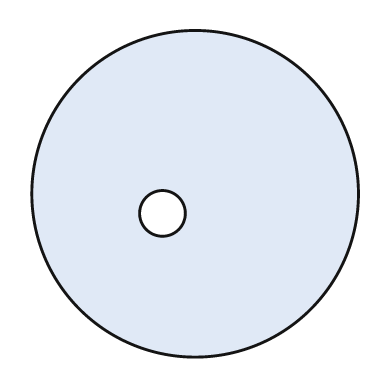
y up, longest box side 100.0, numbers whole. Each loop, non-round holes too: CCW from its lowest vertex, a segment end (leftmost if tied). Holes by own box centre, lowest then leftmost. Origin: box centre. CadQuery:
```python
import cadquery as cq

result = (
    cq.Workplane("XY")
    .moveTo(0.0, 0.0)
    .circle(50.0)
    .moveTo(-10.0, -6.0)
    .circle(7.0)
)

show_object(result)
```